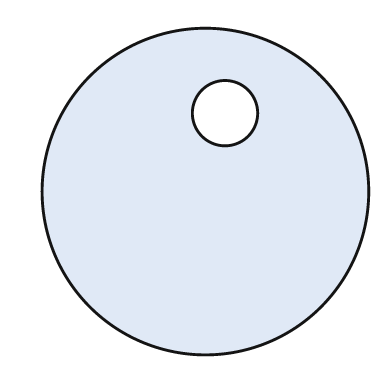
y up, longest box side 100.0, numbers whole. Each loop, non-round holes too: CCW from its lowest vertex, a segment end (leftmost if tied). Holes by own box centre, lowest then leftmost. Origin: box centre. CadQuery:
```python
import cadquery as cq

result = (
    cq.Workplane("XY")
    .moveTo(0.0, 0.0)
    .circle(50.0)
    .moveTo(6.0, 24.0)
    .circle(10.0)
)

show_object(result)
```